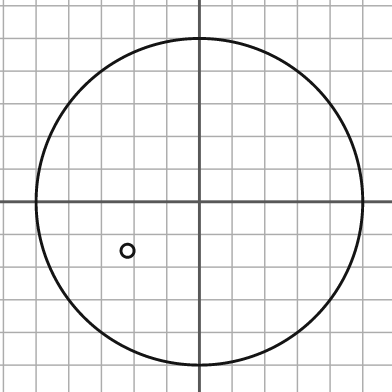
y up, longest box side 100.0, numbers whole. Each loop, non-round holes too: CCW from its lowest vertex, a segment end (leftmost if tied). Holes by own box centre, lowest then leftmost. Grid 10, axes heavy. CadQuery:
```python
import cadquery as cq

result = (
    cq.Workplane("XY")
    .moveTo(0.0, 0.0)
    .circle(50.0)
    .moveTo(-22.0, -15.0)
    .circle(2.0)
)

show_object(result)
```